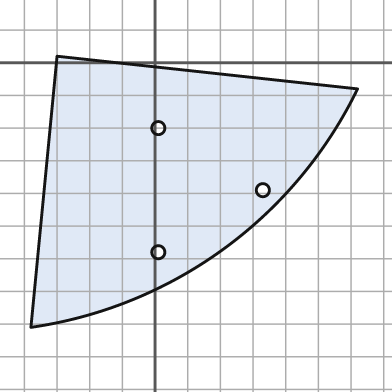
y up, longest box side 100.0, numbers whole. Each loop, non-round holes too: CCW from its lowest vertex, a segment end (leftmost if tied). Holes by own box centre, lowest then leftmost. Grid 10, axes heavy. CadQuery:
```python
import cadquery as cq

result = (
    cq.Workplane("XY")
    .moveTo(-38.0, -81.0)
    .threePointArc((21.0, -57.0), (62.0, -8.0))
    .lineTo(-30.0, 2.0)
    .close()
    .moveTo(1.0, -58.0)
    .circle(2.0)
    .moveTo(33.0, -39.0)
    .circle(2.0)
    .moveTo(1.0, -20.0)
    .circle(2.0)
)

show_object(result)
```